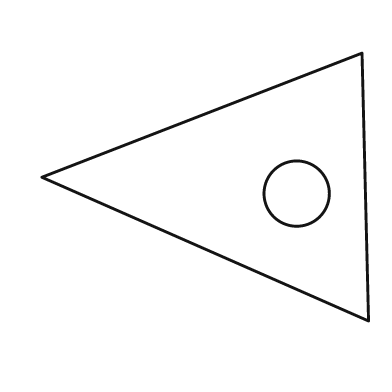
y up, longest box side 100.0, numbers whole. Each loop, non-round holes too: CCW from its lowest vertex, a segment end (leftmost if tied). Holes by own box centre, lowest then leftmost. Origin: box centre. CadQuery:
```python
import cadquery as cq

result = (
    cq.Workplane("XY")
    .moveTo(50.0, -41.0)
    .lineTo(48.0, 41.0)
    .lineTo(-50.0, 3.0)
    .close()
    .moveTo(28.0, -2.0)
    .circle(10.0)
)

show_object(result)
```